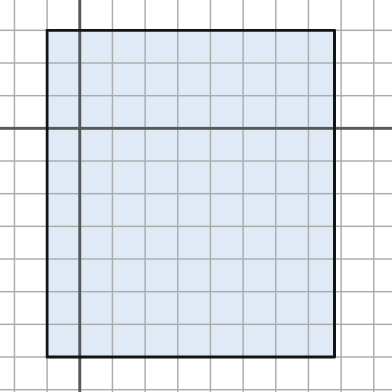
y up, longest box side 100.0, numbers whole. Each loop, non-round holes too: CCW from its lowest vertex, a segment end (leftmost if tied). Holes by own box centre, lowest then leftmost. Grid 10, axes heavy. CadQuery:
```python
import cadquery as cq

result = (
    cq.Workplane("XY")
    .moveTo(-10.0, -70.0)
    .lineTo(78.0, -70.0)
    .lineTo(78.0, 30.0)
    .lineTo(-10.0, 30.0)
    .close()
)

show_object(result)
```